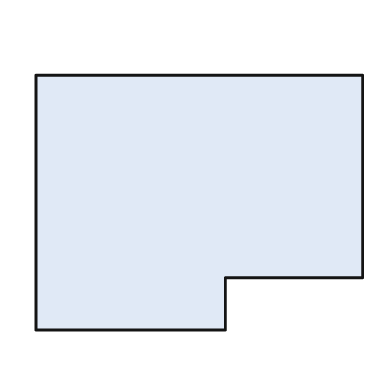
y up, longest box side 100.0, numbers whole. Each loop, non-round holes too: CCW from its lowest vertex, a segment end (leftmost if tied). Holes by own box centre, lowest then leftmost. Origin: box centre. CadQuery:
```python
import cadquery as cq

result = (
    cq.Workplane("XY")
    .moveTo(-50.0, -39.0)
    .lineTo(8.0, -39.0)
    .lineTo(8.0, -23.0)
    .lineTo(50.0, -23.0)
    .lineTo(50.0, 39.0)
    .lineTo(-50.0, 39.0)
    .close()
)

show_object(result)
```